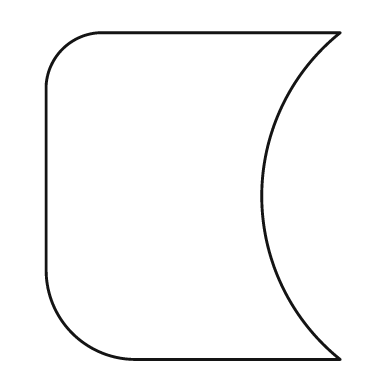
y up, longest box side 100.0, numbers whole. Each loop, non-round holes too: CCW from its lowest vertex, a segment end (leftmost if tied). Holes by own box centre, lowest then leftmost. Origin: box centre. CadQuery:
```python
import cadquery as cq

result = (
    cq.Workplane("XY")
    .moveTo(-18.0, -50.0)
    .lineTo(45.0, -50.0)
    .threePointArc((21.0, 0.0), (45.0, 50.0))
    .lineTo(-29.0, 50.0)
    .threePointArc((-40.0, 45.0), (-45.0, 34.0))
    .lineTo(-45.0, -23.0)
    .threePointArc((-37.0, -42.0), (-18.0, -50.0))
    .close()
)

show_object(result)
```